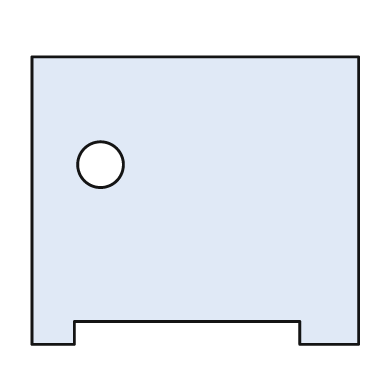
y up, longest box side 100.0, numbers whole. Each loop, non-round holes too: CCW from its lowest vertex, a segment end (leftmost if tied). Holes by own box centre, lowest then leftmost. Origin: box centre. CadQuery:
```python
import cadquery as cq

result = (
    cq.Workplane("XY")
    .moveTo(-50.0, -44.0)
    .lineTo(-37.0, -44.0)
    .lineTo(-37.0, -37.0)
    .lineTo(32.0, -37.0)
    .lineTo(32.0, -44.0)
    .lineTo(50.0, -44.0)
    .lineTo(50.0, 44.0)
    .lineTo(-50.0, 44.0)
    .close()
    .moveTo(-29.0, 11.0)
    .circle(7.0)
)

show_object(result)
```